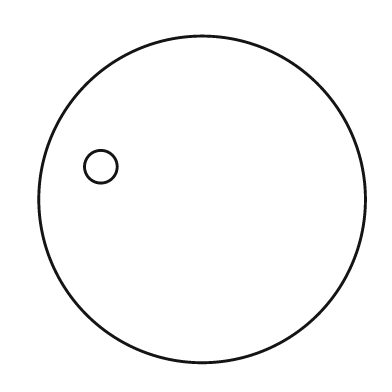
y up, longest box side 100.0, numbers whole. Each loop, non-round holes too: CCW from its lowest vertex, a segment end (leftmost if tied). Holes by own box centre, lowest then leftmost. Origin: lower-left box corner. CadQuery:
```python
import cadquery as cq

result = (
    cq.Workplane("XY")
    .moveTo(50.0, 50.0)
    .circle(50.0)
    .moveTo(19.0, 60.0)
    .circle(5.0)
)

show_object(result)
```